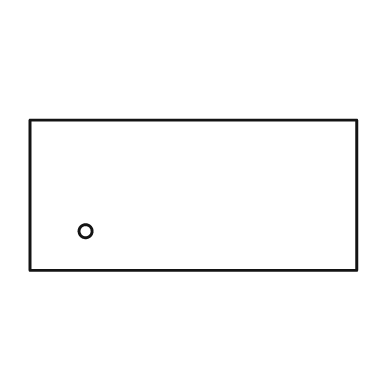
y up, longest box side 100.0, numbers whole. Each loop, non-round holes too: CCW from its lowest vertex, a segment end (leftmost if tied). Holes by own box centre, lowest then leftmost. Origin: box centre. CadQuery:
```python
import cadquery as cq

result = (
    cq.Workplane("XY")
    .moveTo(-50.0, -23.0)
    .lineTo(50.0, -23.0)
    .lineTo(50.0, 23.0)
    .lineTo(-50.0, 23.0)
    .close()
    .moveTo(-33.0, -11.0)
    .circle(2.0)
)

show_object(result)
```